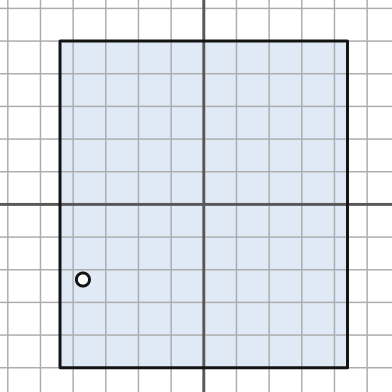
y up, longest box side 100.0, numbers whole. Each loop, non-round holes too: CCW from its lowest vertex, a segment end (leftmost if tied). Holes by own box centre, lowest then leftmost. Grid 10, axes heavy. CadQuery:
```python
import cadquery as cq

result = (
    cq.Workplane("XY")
    .moveTo(-44.0, -50.0)
    .lineTo(44.0, -50.0)
    .lineTo(44.0, 50.0)
    .lineTo(-44.0, 50.0)
    .close()
    .moveTo(-37.0, -23.0)
    .circle(2.0)
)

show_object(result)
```